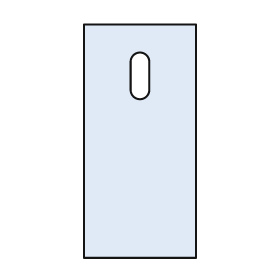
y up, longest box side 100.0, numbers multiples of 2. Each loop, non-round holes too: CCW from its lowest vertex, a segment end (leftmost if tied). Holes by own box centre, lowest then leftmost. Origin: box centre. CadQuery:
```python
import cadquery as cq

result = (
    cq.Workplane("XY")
    .moveTo(-24.0, -50.0)
    .lineTo(24.0, -50.0)
    .lineTo(24.0, 50.0)
    .lineTo(-24.0, 50.0)
    .close()
    .moveTo(-4.0, 22.0)
    .threePointArc((0.0, 18.0), (4.0, 22.0))
    .lineTo(4.0, 34.0)
    .threePointArc((0.0, 38.0), (-4.0, 34.0))
    .close()
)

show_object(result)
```